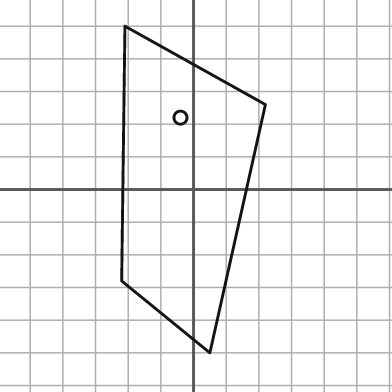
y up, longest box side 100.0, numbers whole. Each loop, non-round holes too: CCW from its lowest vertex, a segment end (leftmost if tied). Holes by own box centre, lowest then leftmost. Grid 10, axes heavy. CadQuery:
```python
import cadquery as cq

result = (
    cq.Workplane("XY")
    .moveTo(5.0, -50.0)
    .lineTo(22.0, 26.0)
    .lineTo(-21.0, 50.0)
    .lineTo(-22.0, -28.0)
    .close()
    .moveTo(-4.0, 22.0)
    .circle(2.0)
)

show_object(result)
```